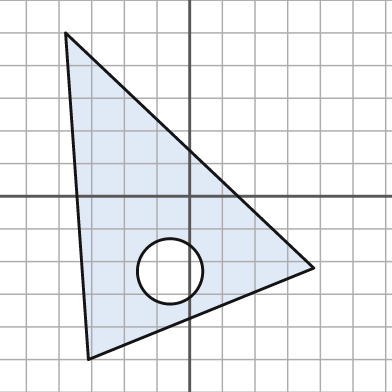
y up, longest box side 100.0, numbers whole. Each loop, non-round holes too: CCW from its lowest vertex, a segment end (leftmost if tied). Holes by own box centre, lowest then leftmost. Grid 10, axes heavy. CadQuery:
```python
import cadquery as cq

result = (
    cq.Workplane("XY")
    .moveTo(-31.0, -50.0)
    .lineTo(38.0, -22.0)
    .lineTo(-38.0, 50.0)
    .close()
    .moveTo(-6.0, -23.0)
    .circle(10.0)
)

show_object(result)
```